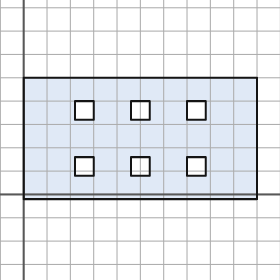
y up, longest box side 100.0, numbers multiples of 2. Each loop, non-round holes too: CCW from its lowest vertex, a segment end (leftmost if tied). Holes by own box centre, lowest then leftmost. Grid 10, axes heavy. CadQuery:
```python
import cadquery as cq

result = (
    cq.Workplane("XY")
    .moveTo(0.0, -2.0)
    .lineTo(100.0, -2.0)
    .lineTo(100.0, 50.0)
    .lineTo(0.0, 50.0)
    .close()
    .moveTo(22.0, 8.0)
    .lineTo(30.0, 8.0)
    .lineTo(30.0, 16.0)
    .lineTo(22.0, 16.0)
    .close()
    .moveTo(46.0, 8.0)
    .lineTo(54.0, 8.0)
    .lineTo(54.0, 16.0)
    .lineTo(46.0, 16.0)
    .close()
    .moveTo(70.0, 8.0)
    .lineTo(78.0, 8.0)
    .lineTo(78.0, 16.0)
    .lineTo(70.0, 16.0)
    .close()
    .moveTo(22.0, 32.0)
    .lineTo(30.0, 32.0)
    .lineTo(30.0, 40.0)
    .lineTo(22.0, 40.0)
    .close()
    .moveTo(46.0, 32.0)
    .lineTo(54.0, 32.0)
    .lineTo(54.0, 40.0)
    .lineTo(46.0, 40.0)
    .close()
    .moveTo(70.0, 32.0)
    .lineTo(78.0, 32.0)
    .lineTo(78.0, 40.0)
    .lineTo(70.0, 40.0)
    .close()
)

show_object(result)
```